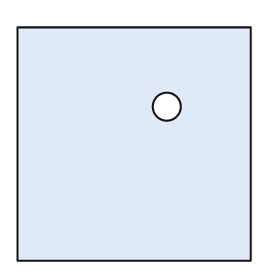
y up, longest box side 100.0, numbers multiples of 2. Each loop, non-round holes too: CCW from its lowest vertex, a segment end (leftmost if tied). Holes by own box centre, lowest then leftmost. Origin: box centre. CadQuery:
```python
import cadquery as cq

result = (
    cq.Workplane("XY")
    .moveTo(-50.0, -50.0)
    .lineTo(50.0, -50.0)
    .lineTo(50.0, 50.0)
    .lineTo(-50.0, 50.0)
    .close()
    .moveTo(14.0, 16.0)
    .circle(6.0)
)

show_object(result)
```